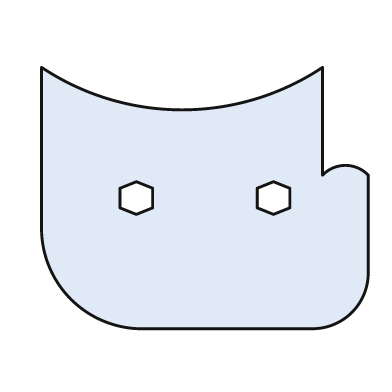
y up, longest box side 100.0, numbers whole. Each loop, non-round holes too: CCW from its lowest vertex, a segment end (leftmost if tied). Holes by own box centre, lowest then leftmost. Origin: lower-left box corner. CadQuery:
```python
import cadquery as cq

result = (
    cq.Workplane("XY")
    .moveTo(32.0, 0.0)
    .lineTo(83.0, 0.0)
    .threePointArc((95.0, 5.0), (100.0, 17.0))
    .lineTo(100.0, 47.0)
    .threePointArc((93.0, 50.0), (86.0, 47.0))
    .lineTo(86.0, 80.0)
    .threePointArc((43.0, 67.0), (0.0, 80.0))
    .lineTo(0.0, 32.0)
    .threePointArc((9.0, 9.0), (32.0, 0.0))
    .close()
    .moveTo(29.0, 35.0)
    .lineTo(34.0, 37.0)
    .lineTo(34.0, 43.0)
    .lineTo(29.0, 45.0)
    .lineTo(24.0, 43.0)
    .lineTo(24.0, 37.0)
    .close()
    .moveTo(71.0, 35.0)
    .lineTo(76.0, 37.0)
    .lineTo(76.0, 43.0)
    .lineTo(71.0, 45.0)
    .lineTo(66.0, 43.0)
    .lineTo(66.0, 37.0)
    .close()
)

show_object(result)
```